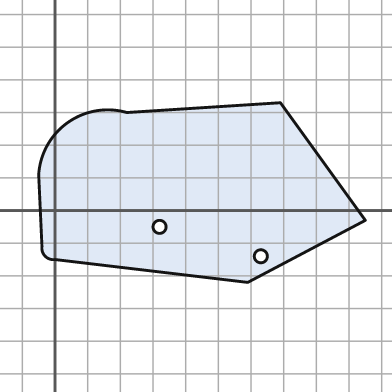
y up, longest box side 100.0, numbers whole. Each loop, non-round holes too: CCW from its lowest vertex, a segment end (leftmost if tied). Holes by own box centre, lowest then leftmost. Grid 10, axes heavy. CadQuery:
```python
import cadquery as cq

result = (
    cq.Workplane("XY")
    .moveTo(59.0, -22.0)
    .lineTo(95.0, -3.0)
    .lineTo(69.0, 33.0)
    .lineTo(22.0, 30.0)
    .threePointArc((4.0, 27.0), (-5.0, 11.0))
    .lineTo(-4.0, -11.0)
    .threePointArc((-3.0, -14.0), (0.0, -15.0))
    .close()
    .moveTo(63.0, -14.0)
    .circle(2.0)
    .moveTo(32.0, -5.0)
    .circle(2.0)
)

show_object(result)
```